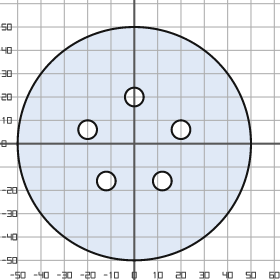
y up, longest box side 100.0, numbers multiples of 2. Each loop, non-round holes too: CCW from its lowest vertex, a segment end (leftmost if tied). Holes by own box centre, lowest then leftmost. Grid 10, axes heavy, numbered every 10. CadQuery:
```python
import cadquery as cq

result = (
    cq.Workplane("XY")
    .moveTo(0.0, 0.0)
    .circle(50.0)
    .moveTo(-12.0, -16.0)
    .circle(4.0)
    .moveTo(12.0, -16.0)
    .circle(4.0)
    .moveTo(-20.0, 6.0)
    .circle(4.0)
    .moveTo(20.0, 6.0)
    .circle(4.0)
    .moveTo(0.0, 20.0)
    .circle(4.0)
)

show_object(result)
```